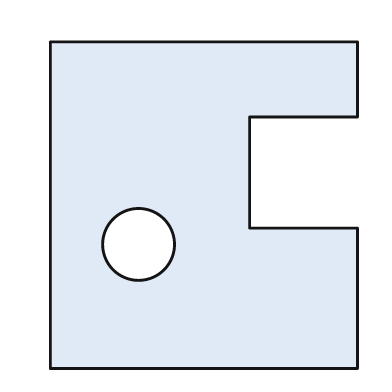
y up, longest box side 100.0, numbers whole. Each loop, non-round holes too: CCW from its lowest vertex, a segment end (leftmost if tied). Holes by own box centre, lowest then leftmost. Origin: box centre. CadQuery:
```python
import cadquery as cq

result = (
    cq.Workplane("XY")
    .moveTo(-47.0, -50.0)
    .lineTo(47.0, -50.0)
    .lineTo(47.0, -7.0)
    .lineTo(14.0, -7.0)
    .lineTo(14.0, 27.0)
    .lineTo(47.0, 27.0)
    .lineTo(47.0, 50.0)
    .lineTo(-47.0, 50.0)
    .close()
    .moveTo(-20.0, -12.0)
    .circle(11.0)
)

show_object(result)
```